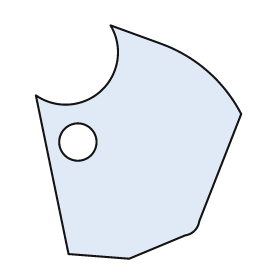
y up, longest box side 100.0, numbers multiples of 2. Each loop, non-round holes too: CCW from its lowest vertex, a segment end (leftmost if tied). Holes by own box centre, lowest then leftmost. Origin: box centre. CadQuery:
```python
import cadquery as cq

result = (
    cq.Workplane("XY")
    .moveTo(-4.0, -50.0)
    .lineTo(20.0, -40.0)
    .threePointArc((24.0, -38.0), (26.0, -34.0))
    .lineTo(44.0, 12.0)
    .threePointArc((30.0, 30.0), (10.0, 42.0))
    .lineTo(-12.0, 50.0)
    .threePointArc((-16.0, 22.0), (-44.0, 20.0))
    .lineTo(-30.0, -48.0)
    .close()
    .moveTo(-26.0, 0.0)
    .circle(8.0)
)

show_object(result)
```